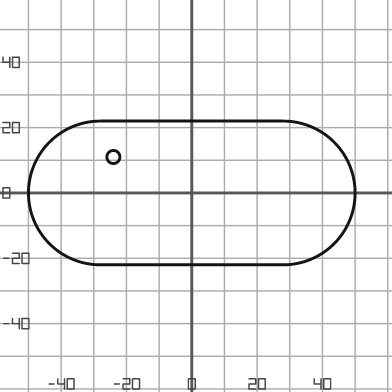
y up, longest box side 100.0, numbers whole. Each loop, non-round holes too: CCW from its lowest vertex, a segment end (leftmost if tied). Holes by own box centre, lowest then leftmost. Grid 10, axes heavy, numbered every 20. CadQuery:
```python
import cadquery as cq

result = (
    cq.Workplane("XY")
    .moveTo(-28.0, -22.0)
    .lineTo(28.0, -22.0)
    .threePointArc((50.0, 0.0), (28.0, 22.0))
    .lineTo(-28.0, 22.0)
    .threePointArc((-50.0, 0.0), (-28.0, -22.0))
    .close()
    .moveTo(-24.0, 11.0)
    .circle(2.0)
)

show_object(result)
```